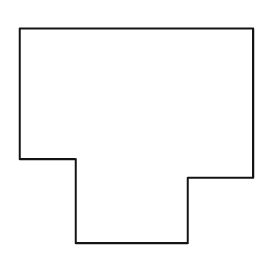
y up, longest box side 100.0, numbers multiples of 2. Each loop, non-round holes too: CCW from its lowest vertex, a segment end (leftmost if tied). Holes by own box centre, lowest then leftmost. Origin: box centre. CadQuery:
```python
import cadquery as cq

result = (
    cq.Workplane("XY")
    .moveTo(-26.0, -46.0)
    .lineTo(22.0, -46.0)
    .lineTo(22.0, -18.0)
    .lineTo(50.0, -18.0)
    .lineTo(50.0, 46.0)
    .lineTo(-50.0, 46.0)
    .lineTo(-50.0, -10.0)
    .lineTo(-26.0, -10.0)
    .close()
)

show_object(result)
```